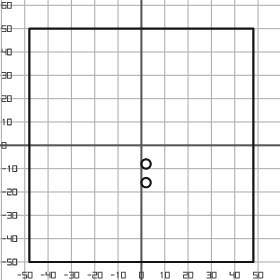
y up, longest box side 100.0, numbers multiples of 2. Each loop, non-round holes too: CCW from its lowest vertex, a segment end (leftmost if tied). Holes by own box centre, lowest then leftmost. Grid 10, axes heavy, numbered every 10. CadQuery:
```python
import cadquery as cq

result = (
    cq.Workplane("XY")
    .moveTo(-48.0, -50.0)
    .lineTo(48.0, -50.0)
    .lineTo(48.0, 50.0)
    .lineTo(-48.0, 50.0)
    .close()
    .moveTo(2.0, -16.0)
    .circle(2.0)
    .moveTo(2.0, -8.0)
    .circle(2.0)
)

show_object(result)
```